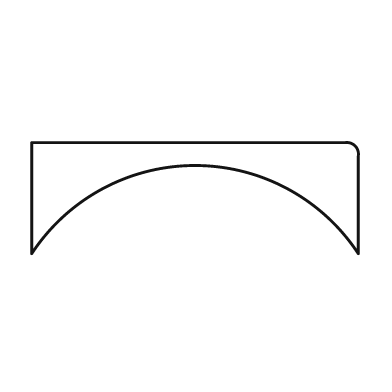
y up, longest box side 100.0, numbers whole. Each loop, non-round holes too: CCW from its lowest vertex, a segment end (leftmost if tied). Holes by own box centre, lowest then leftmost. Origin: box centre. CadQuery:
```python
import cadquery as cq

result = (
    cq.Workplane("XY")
    .moveTo(-50.0, -17.0)
    .threePointArc((0.0, 10.0), (50.0, -17.0))
    .lineTo(50.0, 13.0)
    .threePointArc((49.0, 16.0), (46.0, 17.0))
    .lineTo(-50.0, 17.0)
    .close()
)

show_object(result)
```